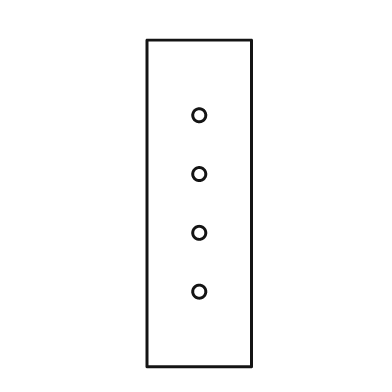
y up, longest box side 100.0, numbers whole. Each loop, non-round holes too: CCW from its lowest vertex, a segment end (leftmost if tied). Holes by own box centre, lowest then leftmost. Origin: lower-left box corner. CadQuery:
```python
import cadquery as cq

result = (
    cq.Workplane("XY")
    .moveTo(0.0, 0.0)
    .lineTo(32.0, 0.0)
    .lineTo(32.0, 100.0)
    .lineTo(0.0, 100.0)
    .close()
    .moveTo(16.0, 23.0)
    .circle(2.0)
    .moveTo(16.0, 41.0)
    .circle(2.0)
    .moveTo(16.0, 59.0)
    .circle(2.0)
    .moveTo(16.0, 77.0)
    .circle(2.0)
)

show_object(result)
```